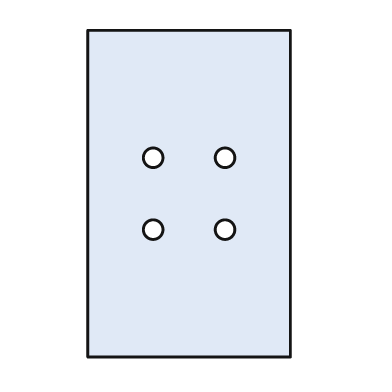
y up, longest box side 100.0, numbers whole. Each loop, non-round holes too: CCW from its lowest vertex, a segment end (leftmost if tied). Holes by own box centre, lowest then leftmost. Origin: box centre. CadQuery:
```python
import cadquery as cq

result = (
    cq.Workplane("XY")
    .moveTo(-31.0, -50.0)
    .lineTo(31.0, -50.0)
    .lineTo(31.0, 50.0)
    .lineTo(-31.0, 50.0)
    .close()
    .moveTo(-11.0, -11.0)
    .circle(3.0)
    .moveTo(11.0, -11.0)
    .circle(3.0)
    .moveTo(-11.0, 11.0)
    .circle(3.0)
    .moveTo(11.0, 11.0)
    .circle(3.0)
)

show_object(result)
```